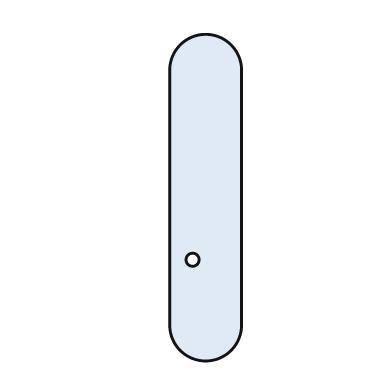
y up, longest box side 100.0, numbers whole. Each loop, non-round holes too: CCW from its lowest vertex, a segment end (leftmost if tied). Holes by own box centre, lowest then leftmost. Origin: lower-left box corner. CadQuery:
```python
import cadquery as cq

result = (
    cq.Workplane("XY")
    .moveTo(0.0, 11.0)
    .threePointArc((11.0, 0.0), (22.0, 11.0))
    .lineTo(22.0, 89.0)
    .threePointArc((11.0, 100.0), (0.0, 89.0))
    .close()
    .moveTo(7.0, 31.0)
    .circle(2.0)
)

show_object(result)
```